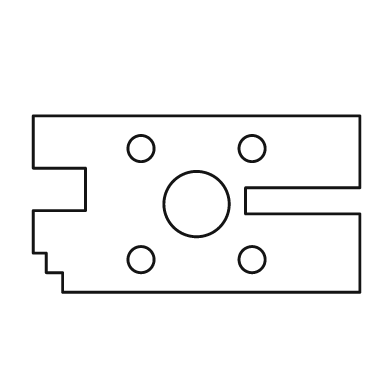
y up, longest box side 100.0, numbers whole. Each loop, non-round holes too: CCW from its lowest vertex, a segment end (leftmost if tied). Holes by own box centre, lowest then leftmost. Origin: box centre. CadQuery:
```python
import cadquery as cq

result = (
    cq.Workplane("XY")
    .moveTo(-41.0, -27.0)
    .lineTo(50.0, -27.0)
    .lineTo(50.0, -3.0)
    .lineTo(15.0, -3.0)
    .lineTo(15.0, 5.0)
    .lineTo(50.0, 5.0)
    .lineTo(50.0, 27.0)
    .lineTo(-50.0, 27.0)
    .lineTo(-50.0, 11.0)
    .lineTo(-34.0, 11.0)
    .lineTo(-34.0, -2.0)
    .lineTo(-50.0, -2.0)
    .lineTo(-50.0, -15.0)
    .lineTo(-46.0, -15.0)
    .lineTo(-46.0, -21.0)
    .lineTo(-41.0, -21.0)
    .close()
    .moveTo(-17.0, -17.0)
    .circle(4.0)
    .moveTo(17.0, -17.0)
    .circle(4.0)
    .moveTo(0.0, 0.0)
    .circle(10.0)
    .moveTo(-17.0, 17.0)
    .circle(4.0)
    .moveTo(17.0, 17.0)
    .circle(4.0)
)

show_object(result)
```